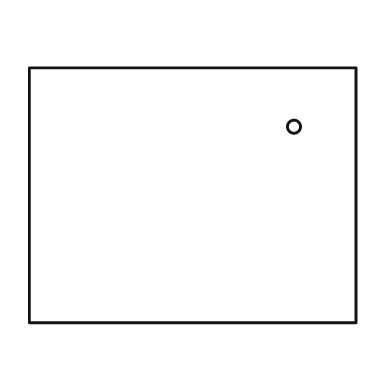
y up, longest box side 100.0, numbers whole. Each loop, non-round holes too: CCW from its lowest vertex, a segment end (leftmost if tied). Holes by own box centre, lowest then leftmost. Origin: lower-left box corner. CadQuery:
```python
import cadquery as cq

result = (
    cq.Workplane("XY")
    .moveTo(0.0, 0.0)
    .lineTo(100.0, 0.0)
    .lineTo(100.0, 78.0)
    .lineTo(0.0, 78.0)
    .close()
    .moveTo(81.0, 60.0)
    .circle(2.0)
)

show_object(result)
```